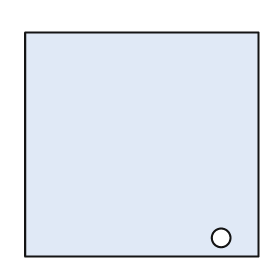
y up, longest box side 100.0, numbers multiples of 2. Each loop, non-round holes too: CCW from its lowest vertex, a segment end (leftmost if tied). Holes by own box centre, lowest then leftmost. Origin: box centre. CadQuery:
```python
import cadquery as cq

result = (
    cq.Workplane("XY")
    .moveTo(-50.0, -48.0)
    .lineTo(50.0, -48.0)
    .lineTo(50.0, 48.0)
    .lineTo(-50.0, 48.0)
    .close()
    .moveTo(34.0, -40.0)
    .circle(4.0)
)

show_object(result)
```